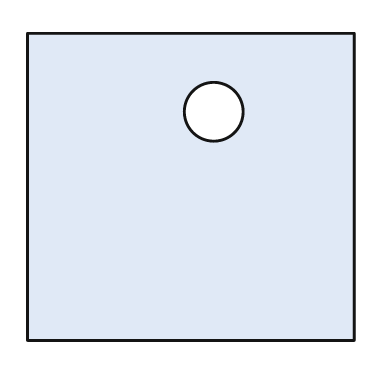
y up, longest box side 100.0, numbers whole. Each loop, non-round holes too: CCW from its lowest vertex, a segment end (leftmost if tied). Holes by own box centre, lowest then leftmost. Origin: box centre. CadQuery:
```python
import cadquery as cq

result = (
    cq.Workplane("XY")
    .moveTo(-50.0, -47.0)
    .lineTo(50.0, -47.0)
    .lineTo(50.0, 47.0)
    .lineTo(-50.0, 47.0)
    .close()
    .moveTo(7.0, 23.0)
    .circle(9.0)
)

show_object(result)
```